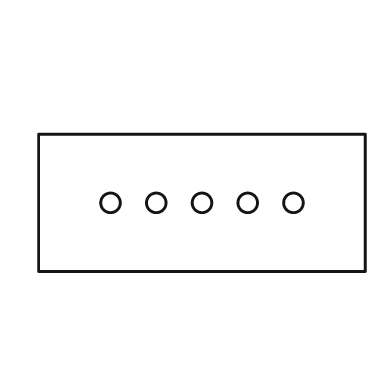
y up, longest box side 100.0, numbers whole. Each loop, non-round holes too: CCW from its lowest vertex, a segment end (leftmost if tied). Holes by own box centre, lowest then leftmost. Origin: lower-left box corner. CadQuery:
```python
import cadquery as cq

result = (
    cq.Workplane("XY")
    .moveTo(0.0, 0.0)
    .lineTo(100.0, 0.0)
    .lineTo(100.0, 42.0)
    .lineTo(0.0, 42.0)
    .close()
    .moveTo(22.0, 21.0)
    .circle(3.0)
    .moveTo(36.0, 21.0)
    .circle(3.0)
    .moveTo(50.0, 21.0)
    .circle(3.0)
    .moveTo(64.0, 21.0)
    .circle(3.0)
    .moveTo(78.0, 21.0)
    .circle(3.0)
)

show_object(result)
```